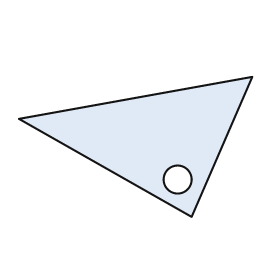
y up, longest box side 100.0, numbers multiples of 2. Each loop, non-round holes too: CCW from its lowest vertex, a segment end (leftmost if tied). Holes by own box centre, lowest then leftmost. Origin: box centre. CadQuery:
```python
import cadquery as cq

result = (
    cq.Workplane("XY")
    .moveTo(24.0, -30.0)
    .lineTo(50.0, 30.0)
    .lineTo(-50.0, 12.0)
    .close()
    .moveTo(18.0, -14.0)
    .circle(6.0)
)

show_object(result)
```